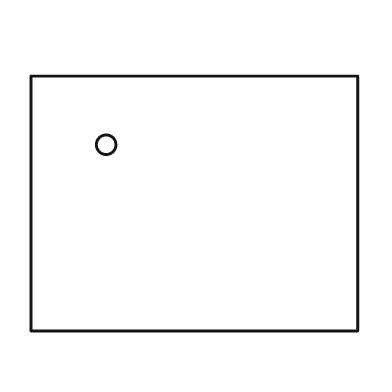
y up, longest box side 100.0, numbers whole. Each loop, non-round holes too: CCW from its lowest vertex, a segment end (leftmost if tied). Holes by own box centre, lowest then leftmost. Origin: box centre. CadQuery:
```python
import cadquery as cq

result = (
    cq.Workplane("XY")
    .moveTo(-50.0, -39.0)
    .lineTo(50.0, -39.0)
    .lineTo(50.0, 39.0)
    .lineTo(-50.0, 39.0)
    .close()
    .moveTo(-27.0, 18.0)
    .circle(3.0)
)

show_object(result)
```